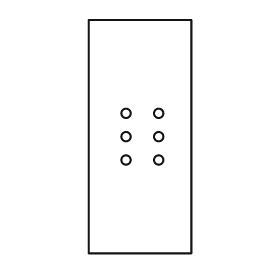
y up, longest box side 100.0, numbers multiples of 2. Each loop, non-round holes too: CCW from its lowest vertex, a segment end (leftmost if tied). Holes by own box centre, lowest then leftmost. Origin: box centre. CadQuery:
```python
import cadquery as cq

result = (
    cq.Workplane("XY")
    .moveTo(-22.0, -50.0)
    .lineTo(22.0, -50.0)
    .lineTo(22.0, 50.0)
    .lineTo(-22.0, 50.0)
    .close()
    .moveTo(-6.0, -10.0)
    .circle(2.0)
    .moveTo(8.0, -10.0)
    .circle(2.0)
    .moveTo(-6.0, 0.0)
    .circle(2.0)
    .moveTo(8.0, 0.0)
    .circle(2.0)
    .moveTo(-6.0, 10.0)
    .circle(2.0)
    .moveTo(8.0, 10.0)
    .circle(2.0)
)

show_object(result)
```